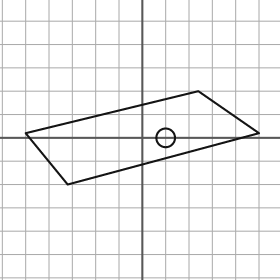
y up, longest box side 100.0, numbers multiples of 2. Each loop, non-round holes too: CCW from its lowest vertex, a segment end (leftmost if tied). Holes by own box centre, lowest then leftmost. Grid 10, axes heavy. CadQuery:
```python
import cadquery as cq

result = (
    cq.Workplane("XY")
    .moveTo(-32.0, -20.0)
    .lineTo(50.0, 2.0)
    .lineTo(24.0, 20.0)
    .lineTo(-50.0, 2.0)
    .close()
    .moveTo(10.0, 0.0)
    .circle(4.0)
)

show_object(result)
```